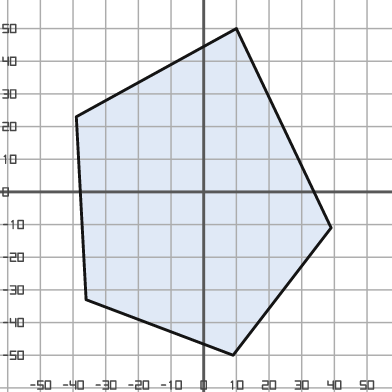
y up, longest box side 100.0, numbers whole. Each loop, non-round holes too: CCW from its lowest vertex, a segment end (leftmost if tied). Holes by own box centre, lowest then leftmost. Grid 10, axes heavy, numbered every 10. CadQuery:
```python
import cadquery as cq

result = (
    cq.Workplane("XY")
    .moveTo(9.0, -50.0)
    .lineTo(39.0, -11.0)
    .lineTo(10.0, 50.0)
    .lineTo(-39.0, 23.0)
    .lineTo(-36.0, -33.0)
    .close()
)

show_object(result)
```